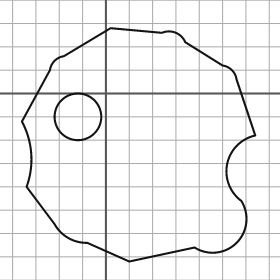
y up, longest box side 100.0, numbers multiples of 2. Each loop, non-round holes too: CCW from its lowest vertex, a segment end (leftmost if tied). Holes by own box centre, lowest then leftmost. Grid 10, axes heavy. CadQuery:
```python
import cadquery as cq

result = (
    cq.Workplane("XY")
    .moveTo(10.0, -72.0)
    .lineTo(38.0, -66.0)
    .threePointArc((56.0, -64.0), (58.0, -46.0))
    .threePointArc((52.0, -30.0), (64.0, -18.0))
    .lineTo(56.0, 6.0)
    .threePointArc((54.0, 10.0), (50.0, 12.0))
    .lineTo(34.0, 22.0)
    .threePointArc((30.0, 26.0), (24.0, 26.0))
    .lineTo(2.0, 28.0)
    .lineTo(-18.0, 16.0)
    .threePointArc((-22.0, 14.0), (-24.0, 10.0))
    .lineTo(-36.0, -12.0)
    .threePointArc((-32.0, -26.0), (-34.0, -40.0))
    .lineTo(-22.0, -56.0)
    .threePointArc((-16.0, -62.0), (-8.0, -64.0))
    .close()
    .moveTo(-12.0, -10.0)
    .circle(10.0)
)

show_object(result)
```